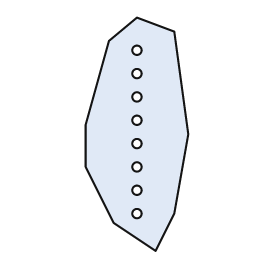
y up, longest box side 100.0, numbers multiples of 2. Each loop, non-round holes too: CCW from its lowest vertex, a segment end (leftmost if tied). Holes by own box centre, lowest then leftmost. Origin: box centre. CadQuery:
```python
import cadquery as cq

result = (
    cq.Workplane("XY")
    .moveTo(8.0, -50.0)
    .lineTo(16.0, -34.0)
    .lineTo(22.0, 0.0)
    .lineTo(16.0, 44.0)
    .lineTo(0.0, 50.0)
    .lineTo(-12.0, 40.0)
    .lineTo(-22.0, 4.0)
    .lineTo(-22.0, -14.0)
    .lineTo(-10.0, -38.0)
    .close()
    .moveTo(0.0, -34.0)
    .circle(2.0)
    .moveTo(0.0, -24.0)
    .circle(2.0)
    .moveTo(0.0, -14.0)
    .circle(2.0)
    .moveTo(0.0, -4.0)
    .circle(2.0)
    .moveTo(0.0, 6.0)
    .circle(2.0)
    .moveTo(0.0, 16.0)
    .circle(2.0)
    .moveTo(0.0, 26.0)
    .circle(2.0)
    .moveTo(0.0, 36.0)
    .circle(2.0)
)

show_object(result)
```